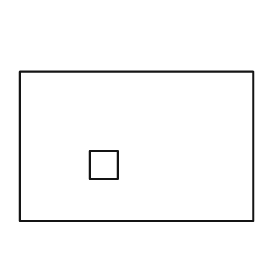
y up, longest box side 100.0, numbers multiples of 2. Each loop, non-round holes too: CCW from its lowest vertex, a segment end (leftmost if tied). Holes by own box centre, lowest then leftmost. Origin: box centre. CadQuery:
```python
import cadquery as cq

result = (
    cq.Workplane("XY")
    .moveTo(-50.0, -32.0)
    .lineTo(50.0, -32.0)
    .lineTo(50.0, 32.0)
    .lineTo(-50.0, 32.0)
    .close()
    .moveTo(-20.0, -14.0)
    .lineTo(-8.0, -14.0)
    .lineTo(-8.0, -2.0)
    .lineTo(-20.0, -2.0)
    .close()
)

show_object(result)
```